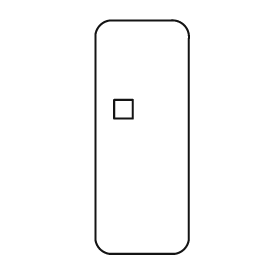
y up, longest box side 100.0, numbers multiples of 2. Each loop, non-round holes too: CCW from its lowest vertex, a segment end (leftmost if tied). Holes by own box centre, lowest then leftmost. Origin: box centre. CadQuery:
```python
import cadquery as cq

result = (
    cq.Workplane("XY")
    .moveTo(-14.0, -50.0)
    .lineTo(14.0, -50.0)
    .threePointArc((18.0, -48.0), (20.0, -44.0))
    .lineTo(20.0, 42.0)
    .threePointArc((18.0, 48.0), (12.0, 50.0))
    .lineTo(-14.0, 50.0)
    .threePointArc((-18.0, 48.0), (-20.0, 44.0))
    .lineTo(-20.0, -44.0)
    .threePointArc((-18.0, -48.0), (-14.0, -50.0))
    .close()
    .moveTo(-12.0, 8.0)
    .lineTo(-4.0, 8.0)
    .lineTo(-4.0, 16.0)
    .lineTo(-12.0, 16.0)
    .close()
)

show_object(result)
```